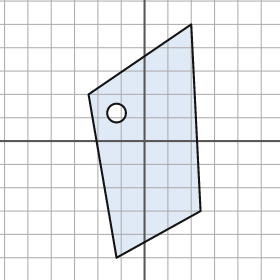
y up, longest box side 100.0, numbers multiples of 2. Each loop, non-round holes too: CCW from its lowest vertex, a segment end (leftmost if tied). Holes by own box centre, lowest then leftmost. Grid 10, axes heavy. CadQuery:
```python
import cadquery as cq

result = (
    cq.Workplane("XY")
    .moveTo(-12.0, -50.0)
    .lineTo(24.0, -30.0)
    .lineTo(20.0, 50.0)
    .lineTo(-24.0, 20.0)
    .close()
    .moveTo(-12.0, 12.0)
    .circle(4.0)
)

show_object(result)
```